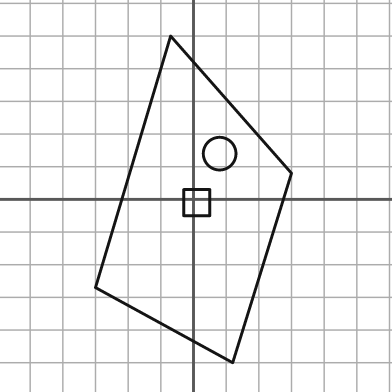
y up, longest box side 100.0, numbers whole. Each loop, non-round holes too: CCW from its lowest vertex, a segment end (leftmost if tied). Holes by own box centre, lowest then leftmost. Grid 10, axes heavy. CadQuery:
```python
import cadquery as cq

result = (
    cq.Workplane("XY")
    .moveTo(12.0, -50.0)
    .lineTo(30.0, 8.0)
    .lineTo(-7.0, 50.0)
    .lineTo(-30.0, -27.0)
    .close()
    .moveTo(-3.0, -5.0)
    .lineTo(5.0, -5.0)
    .lineTo(5.0, 3.0)
    .lineTo(-3.0, 3.0)
    .close()
    .moveTo(8.0, 14.0)
    .circle(5.0)
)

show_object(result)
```